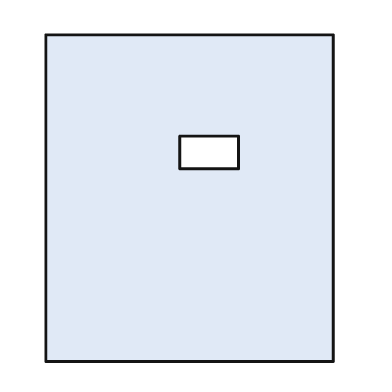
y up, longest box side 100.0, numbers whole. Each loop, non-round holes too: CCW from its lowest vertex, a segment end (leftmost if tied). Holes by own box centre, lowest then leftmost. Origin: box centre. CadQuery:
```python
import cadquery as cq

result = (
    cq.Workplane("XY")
    .moveTo(-44.0, -50.0)
    .lineTo(44.0, -50.0)
    .lineTo(44.0, 50.0)
    .lineTo(-44.0, 50.0)
    .close()
    .moveTo(-3.0, 9.0)
    .lineTo(15.0, 9.0)
    .lineTo(15.0, 19.0)
    .lineTo(-3.0, 19.0)
    .close()
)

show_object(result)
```